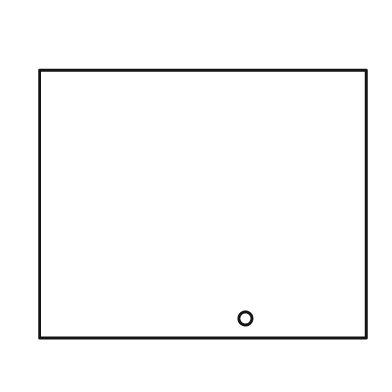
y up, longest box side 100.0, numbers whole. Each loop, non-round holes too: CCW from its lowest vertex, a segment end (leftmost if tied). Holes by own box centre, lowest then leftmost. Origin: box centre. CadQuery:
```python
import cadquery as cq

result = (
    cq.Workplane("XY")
    .moveTo(-50.0, -41.0)
    .lineTo(50.0, -41.0)
    .lineTo(50.0, 41.0)
    .lineTo(-50.0, 41.0)
    .close()
    .moveTo(13.0, -35.0)
    .circle(2.0)
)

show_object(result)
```